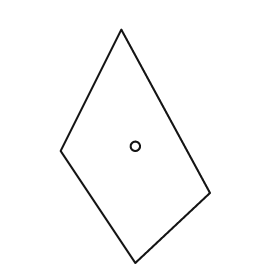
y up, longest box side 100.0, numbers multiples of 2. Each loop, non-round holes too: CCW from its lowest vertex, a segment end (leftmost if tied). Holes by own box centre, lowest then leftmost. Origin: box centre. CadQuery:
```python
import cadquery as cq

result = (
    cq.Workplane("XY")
    .moveTo(0.0, -50.0)
    .lineTo(32.0, -20.0)
    .lineTo(-6.0, 50.0)
    .lineTo(-32.0, -2.0)
    .close()
    .moveTo(0.0, 0.0)
    .circle(2.0)
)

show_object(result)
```